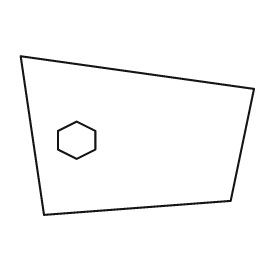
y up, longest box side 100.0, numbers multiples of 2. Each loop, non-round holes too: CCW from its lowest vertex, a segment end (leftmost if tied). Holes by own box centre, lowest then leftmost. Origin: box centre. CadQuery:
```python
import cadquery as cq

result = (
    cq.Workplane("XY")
    .moveTo(-40.0, -34.0)
    .lineTo(40.0, -28.0)
    .lineTo(50.0, 20.0)
    .lineTo(-50.0, 34.0)
    .close()
    .moveTo(-26.0, -10.0)
    .lineTo(-18.0, -6.0)
    .lineTo(-18.0, 2.0)
    .lineTo(-26.0, 6.0)
    .lineTo(-34.0, 2.0)
    .lineTo(-34.0, -6.0)
    .close()
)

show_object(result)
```